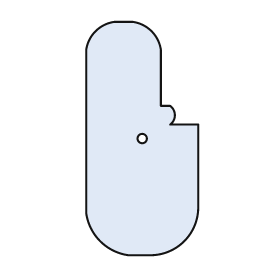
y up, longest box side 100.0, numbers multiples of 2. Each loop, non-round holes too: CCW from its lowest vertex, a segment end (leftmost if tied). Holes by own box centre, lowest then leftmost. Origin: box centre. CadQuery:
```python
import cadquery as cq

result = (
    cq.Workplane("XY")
    .moveTo(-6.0, -50.0)
    .lineTo(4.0, -50.0)
    .threePointArc((18.0, -44.0), (24.0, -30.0))
    .lineTo(24.0, 6.0)
    .lineTo(12.0, 6.0)
    .threePointArc((14.0, 10.0), (12.0, 14.0))
    .lineTo(8.0, 14.0)
    .lineTo(8.0, 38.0)
    .threePointArc((4.0, 46.0), (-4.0, 50.0))
    .lineTo(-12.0, 50.0)
    .threePointArc((-20.0, 46.0), (-24.0, 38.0))
    .lineTo(-24.0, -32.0)
    .threePointArc((-18.0, -44.0), (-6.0, -50.0))
    .close()
    .moveTo(0.0, 0.0)
    .circle(2.0)
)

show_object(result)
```